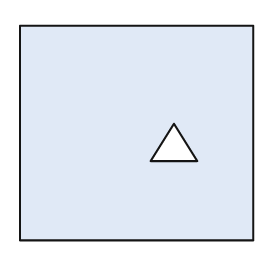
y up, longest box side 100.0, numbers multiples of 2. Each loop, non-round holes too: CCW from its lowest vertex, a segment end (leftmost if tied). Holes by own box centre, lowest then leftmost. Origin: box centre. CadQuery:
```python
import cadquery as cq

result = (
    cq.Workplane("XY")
    .moveTo(-50.0, -46.0)
    .lineTo(50.0, -46.0)
    .lineTo(50.0, 46.0)
    .lineTo(-50.0, 46.0)
    .close()
    .moveTo(6.0, -12.0)
    .lineTo(26.0, -12.0)
    .lineTo(16.0, 4.0)
    .close()
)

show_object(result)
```